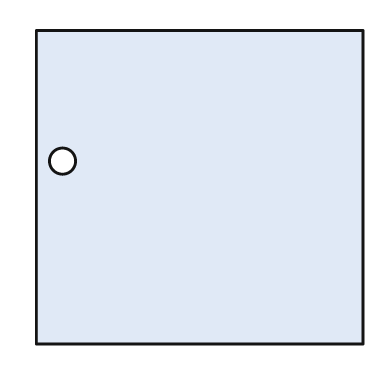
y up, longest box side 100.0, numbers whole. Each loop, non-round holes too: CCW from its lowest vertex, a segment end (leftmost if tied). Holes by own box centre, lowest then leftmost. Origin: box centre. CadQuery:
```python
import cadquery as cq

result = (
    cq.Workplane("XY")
    .moveTo(-50.0, -48.0)
    .lineTo(50.0, -48.0)
    .lineTo(50.0, 48.0)
    .lineTo(-50.0, 48.0)
    .close()
    .moveTo(-42.0, 8.0)
    .circle(4.0)
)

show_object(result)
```